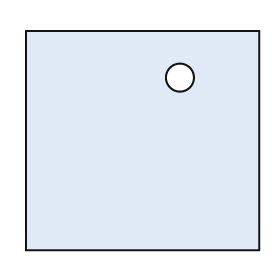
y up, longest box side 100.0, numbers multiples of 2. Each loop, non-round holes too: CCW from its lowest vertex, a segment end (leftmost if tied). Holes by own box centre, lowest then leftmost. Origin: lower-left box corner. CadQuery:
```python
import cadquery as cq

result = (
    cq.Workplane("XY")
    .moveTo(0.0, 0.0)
    .lineTo(100.0, 0.0)
    .lineTo(100.0, 94.0)
    .lineTo(0.0, 94.0)
    .close()
    .moveTo(66.0, 74.0)
    .circle(6.0)
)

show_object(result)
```